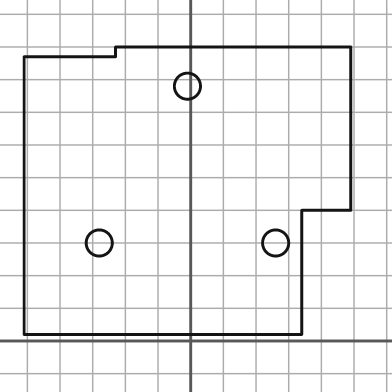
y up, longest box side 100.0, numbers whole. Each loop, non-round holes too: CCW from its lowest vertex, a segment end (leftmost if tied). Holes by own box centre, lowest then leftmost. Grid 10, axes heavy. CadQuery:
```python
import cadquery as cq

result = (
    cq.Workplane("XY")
    .moveTo(-51.0, 2.0)
    .lineTo(34.0, 2.0)
    .lineTo(34.0, 40.0)
    .lineTo(49.0, 40.0)
    .lineTo(49.0, 90.0)
    .lineTo(-23.0, 90.0)
    .lineTo(-23.0, 87.0)
    .lineTo(-51.0, 87.0)
    .close()
    .moveTo(-28.0, 30.0)
    .circle(4.0)
    .moveTo(26.0, 30.0)
    .circle(4.0)
    .moveTo(-1.0, 78.0)
    .circle(4.0)
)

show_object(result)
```